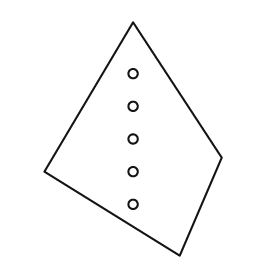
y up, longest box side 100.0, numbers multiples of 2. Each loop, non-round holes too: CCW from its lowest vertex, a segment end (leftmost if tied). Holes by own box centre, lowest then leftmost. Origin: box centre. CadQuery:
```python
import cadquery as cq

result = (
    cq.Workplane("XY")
    .moveTo(20.0, -50.0)
    .lineTo(38.0, -8.0)
    .lineTo(0.0, 50.0)
    .lineTo(-38.0, -14.0)
    .close()
    .moveTo(0.0, -28.0)
    .circle(2.0)
    .moveTo(0.0, -14.0)
    .circle(2.0)
    .moveTo(0.0, 0.0)
    .circle(2.0)
    .moveTo(0.0, 14.0)
    .circle(2.0)
    .moveTo(0.0, 28.0)
    .circle(2.0)
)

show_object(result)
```